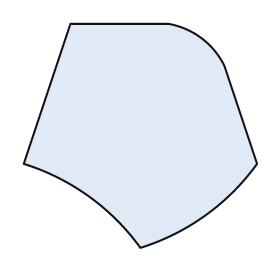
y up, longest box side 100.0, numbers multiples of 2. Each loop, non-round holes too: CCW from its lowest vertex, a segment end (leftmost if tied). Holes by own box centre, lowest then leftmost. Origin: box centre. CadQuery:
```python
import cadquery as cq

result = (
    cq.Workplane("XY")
    .moveTo(0.0, -48.0)
    .threePointArc((28.0, -34.0), (50.0, -12.0))
    .lineTo(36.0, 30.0)
    .threePointArc((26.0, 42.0), (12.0, 48.0))
    .lineTo(-30.0, 48.0)
    .lineTo(-50.0, -12.0)
    .threePointArc((-22.0, -26.0), (0.0, -48.0))
    .close()
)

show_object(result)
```